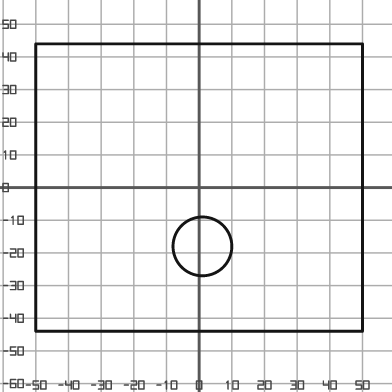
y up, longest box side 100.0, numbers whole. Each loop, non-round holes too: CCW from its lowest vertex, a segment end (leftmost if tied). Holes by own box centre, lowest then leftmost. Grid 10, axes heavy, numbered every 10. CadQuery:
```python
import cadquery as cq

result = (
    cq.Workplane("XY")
    .moveTo(-50.0, -44.0)
    .lineTo(50.0, -44.0)
    .lineTo(50.0, 44.0)
    .lineTo(-50.0, 44.0)
    .close()
    .moveTo(1.0, -18.0)
    .circle(9.0)
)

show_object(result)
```